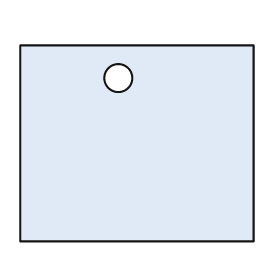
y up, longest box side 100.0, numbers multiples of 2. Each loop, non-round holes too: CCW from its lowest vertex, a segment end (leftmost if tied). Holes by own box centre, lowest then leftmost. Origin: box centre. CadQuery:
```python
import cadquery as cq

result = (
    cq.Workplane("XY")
    .moveTo(-50.0, -42.0)
    .lineTo(50.0, -42.0)
    .lineTo(50.0, 42.0)
    .lineTo(-50.0, 42.0)
    .close()
    .moveTo(-8.0, 28.0)
    .circle(6.0)
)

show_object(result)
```